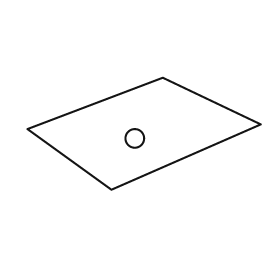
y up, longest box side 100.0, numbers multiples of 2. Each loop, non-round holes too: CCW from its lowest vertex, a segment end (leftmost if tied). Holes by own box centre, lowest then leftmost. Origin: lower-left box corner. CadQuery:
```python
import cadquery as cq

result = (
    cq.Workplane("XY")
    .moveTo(36.0, 0.0)
    .lineTo(100.0, 28.0)
    .lineTo(58.0, 48.0)
    .lineTo(0.0, 26.0)
    .close()
    .moveTo(46.0, 22.0)
    .circle(4.0)
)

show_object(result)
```